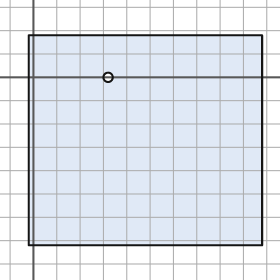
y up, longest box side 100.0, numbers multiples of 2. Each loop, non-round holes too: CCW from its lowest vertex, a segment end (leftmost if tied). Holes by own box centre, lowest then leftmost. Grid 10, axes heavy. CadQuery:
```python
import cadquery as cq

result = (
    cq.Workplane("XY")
    .moveTo(-2.0, -72.0)
    .lineTo(98.0, -72.0)
    .lineTo(98.0, 18.0)
    .lineTo(-2.0, 18.0)
    .close()
    .moveTo(32.0, 0.0)
    .circle(2.0)
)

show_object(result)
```